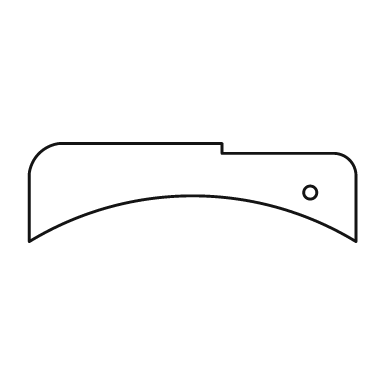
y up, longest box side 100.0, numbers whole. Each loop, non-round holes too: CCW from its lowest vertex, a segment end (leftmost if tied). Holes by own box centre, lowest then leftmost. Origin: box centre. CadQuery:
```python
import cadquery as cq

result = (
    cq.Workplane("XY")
    .moveTo(-50.0, -15.0)
    .threePointArc((0.0, -1.0), (50.0, -15.0))
    .lineTo(50.0, 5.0)
    .threePointArc((48.0, 10.0), (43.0, 12.0))
    .lineTo(9.0, 12.0)
    .lineTo(9.0, 15.0)
    .lineTo(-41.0, 15.0)
    .threePointArc((-47.0, 12.0), (-50.0, 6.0))
    .close()
    .moveTo(36.0, 0.0)
    .circle(2.0)
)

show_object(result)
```